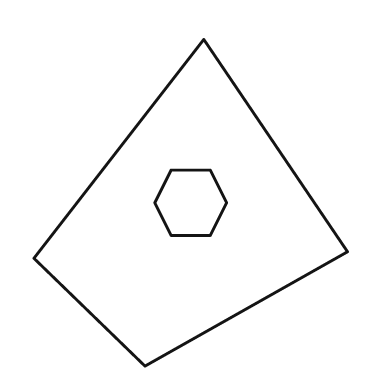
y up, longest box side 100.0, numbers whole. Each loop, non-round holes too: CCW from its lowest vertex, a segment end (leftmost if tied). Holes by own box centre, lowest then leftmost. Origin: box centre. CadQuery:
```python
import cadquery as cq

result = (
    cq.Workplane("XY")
    .moveTo(-14.0, -50.0)
    .lineTo(48.0, -15.0)
    .lineTo(4.0, 50.0)
    .lineTo(-48.0, -17.0)
    .close()
    .moveTo(-6.0, -10.0)
    .lineTo(6.0, -10.0)
    .lineTo(11.0, 0.0)
    .lineTo(6.0, 10.0)
    .lineTo(-6.0, 10.0)
    .lineTo(-11.0, 0.0)
    .close()
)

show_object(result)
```